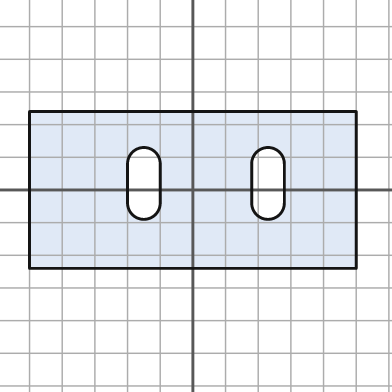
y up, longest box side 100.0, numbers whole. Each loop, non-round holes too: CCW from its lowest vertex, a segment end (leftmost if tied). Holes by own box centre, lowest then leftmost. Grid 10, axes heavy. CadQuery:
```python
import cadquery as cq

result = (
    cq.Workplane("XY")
    .moveTo(-50.0, -24.0)
    .lineTo(50.0, -24.0)
    .lineTo(50.0, 24.0)
    .lineTo(-50.0, 24.0)
    .close()
    .moveTo(-20.0, -4.0)
    .threePointArc((-15.0, -9.0), (-10.0, -4.0))
    .lineTo(-10.0, 8.0)
    .threePointArc((-15.0, 13.0), (-20.0, 8.0))
    .close()
    .moveTo(18.0, -4.0)
    .threePointArc((23.0, -9.0), (28.0, -4.0))
    .lineTo(28.0, 8.0)
    .threePointArc((23.0, 13.0), (18.0, 8.0))
    .close()
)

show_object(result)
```